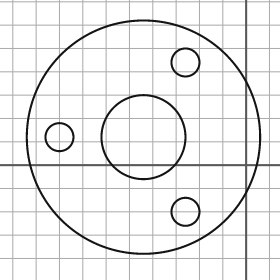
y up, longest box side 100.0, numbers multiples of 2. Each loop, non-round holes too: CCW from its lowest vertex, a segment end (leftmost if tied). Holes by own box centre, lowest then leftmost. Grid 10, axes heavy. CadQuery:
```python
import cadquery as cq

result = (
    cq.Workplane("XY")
    .moveTo(-44.0, 12.0)
    .circle(50.0)
    .moveTo(-26.0, -20.0)
    .circle(6.0)
    .moveTo(-80.0, 12.0)
    .circle(6.0)
    .moveTo(-44.0, 12.0)
    .circle(18.0)
    .moveTo(-26.0, 44.0)
    .circle(6.0)
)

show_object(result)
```